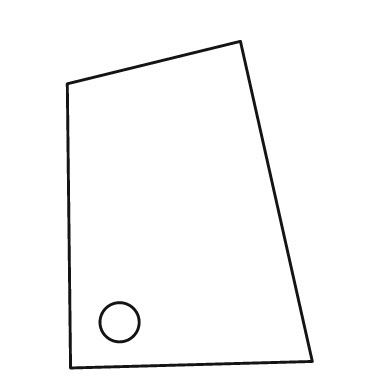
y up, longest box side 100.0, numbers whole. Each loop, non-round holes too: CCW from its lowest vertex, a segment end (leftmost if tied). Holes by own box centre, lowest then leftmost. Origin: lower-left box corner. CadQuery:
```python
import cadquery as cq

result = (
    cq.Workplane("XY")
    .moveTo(1.0, 0.0)
    .lineTo(75.0, 2.0)
    .lineTo(53.0, 100.0)
    .lineTo(0.0, 87.0)
    .close()
    .moveTo(16.0, 14.0)
    .circle(6.0)
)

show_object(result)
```